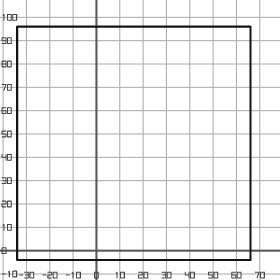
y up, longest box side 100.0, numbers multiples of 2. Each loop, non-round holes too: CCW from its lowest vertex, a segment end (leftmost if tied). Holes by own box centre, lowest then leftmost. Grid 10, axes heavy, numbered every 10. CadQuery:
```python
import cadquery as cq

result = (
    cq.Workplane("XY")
    .moveTo(-34.0, -4.0)
    .lineTo(66.0, -4.0)
    .lineTo(66.0, 96.0)
    .lineTo(-34.0, 96.0)
    .close()
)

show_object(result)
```